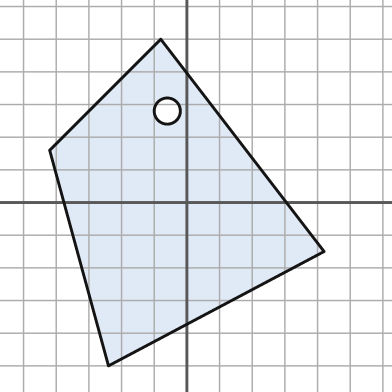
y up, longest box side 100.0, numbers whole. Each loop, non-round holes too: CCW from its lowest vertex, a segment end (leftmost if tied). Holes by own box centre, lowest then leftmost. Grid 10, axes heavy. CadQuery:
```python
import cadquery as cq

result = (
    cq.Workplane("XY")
    .moveTo(-24.0, -50.0)
    .lineTo(42.0, -15.0)
    .lineTo(-8.0, 50.0)
    .lineTo(-42.0, 16.0)
    .close()
    .moveTo(-6.0, 28.0)
    .circle(4.0)
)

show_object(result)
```